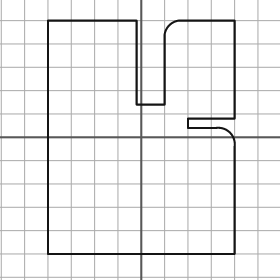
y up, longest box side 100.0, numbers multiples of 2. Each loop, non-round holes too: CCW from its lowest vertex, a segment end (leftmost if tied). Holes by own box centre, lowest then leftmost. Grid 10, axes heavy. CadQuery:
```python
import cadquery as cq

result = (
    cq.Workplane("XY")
    .moveTo(-40.0, -50.0)
    .lineTo(40.0, -50.0)
    .lineTo(40.0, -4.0)
    .threePointArc((38.0, 2.0), (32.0, 4.0))
    .lineTo(20.0, 4.0)
    .lineTo(20.0, 8.0)
    .lineTo(40.0, 8.0)
    .lineTo(40.0, 50.0)
    .lineTo(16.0, 50.0)
    .threePointArc((12.0, 48.0), (10.0, 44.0))
    .lineTo(10.0, 14.0)
    .lineTo(-2.0, 14.0)
    .lineTo(-2.0, 50.0)
    .lineTo(-40.0, 50.0)
    .close()
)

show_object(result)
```